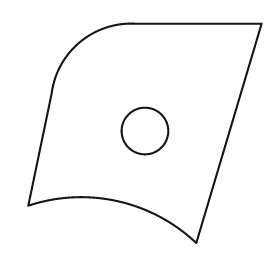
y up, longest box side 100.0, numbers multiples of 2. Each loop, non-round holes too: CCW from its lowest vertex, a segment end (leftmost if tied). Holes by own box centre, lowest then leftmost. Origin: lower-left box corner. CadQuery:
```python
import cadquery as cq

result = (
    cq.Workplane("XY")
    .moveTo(72.0, 0.0)
    .lineTo(100.0, 94.0)
    .lineTo(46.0, 94.0)
    .threePointArc((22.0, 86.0), (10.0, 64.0))
    .lineTo(0.0, 16.0)
    .threePointArc((38.0, 18.0), (72.0, 0.0))
    .close()
    .moveTo(50.0, 48.0)
    .circle(10.0)
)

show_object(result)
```